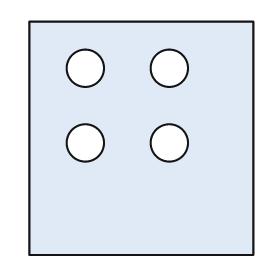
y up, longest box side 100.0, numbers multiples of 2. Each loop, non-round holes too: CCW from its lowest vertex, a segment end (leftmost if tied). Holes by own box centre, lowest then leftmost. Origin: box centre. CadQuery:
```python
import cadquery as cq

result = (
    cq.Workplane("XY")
    .moveTo(-48.0, -50.0)
    .lineTo(48.0, -50.0)
    .lineTo(48.0, 50.0)
    .lineTo(-48.0, 50.0)
    .close()
    .moveTo(-24.0, -2.0)
    .circle(8.0)
    .moveTo(12.0, -2.0)
    .circle(8.0)
    .moveTo(-24.0, 30.0)
    .circle(8.0)
    .moveTo(12.0, 30.0)
    .circle(8.0)
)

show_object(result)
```